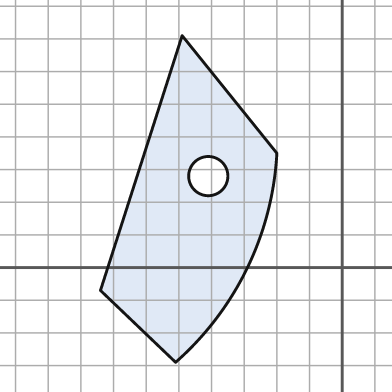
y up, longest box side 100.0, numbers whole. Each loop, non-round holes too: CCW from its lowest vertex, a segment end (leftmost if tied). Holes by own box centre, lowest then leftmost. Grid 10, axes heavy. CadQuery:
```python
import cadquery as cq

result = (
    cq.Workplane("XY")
    .moveTo(-51.0, -29.0)
    .threePointArc((-29.0, 0.0), (-20.0, 35.0))
    .lineTo(-49.0, 71.0)
    .lineTo(-74.0, -7.0)
    .close()
    .moveTo(-41.0, 28.0)
    .circle(6.0)
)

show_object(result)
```